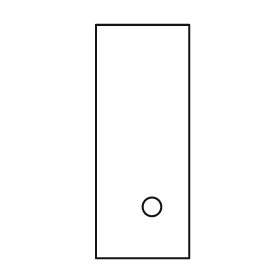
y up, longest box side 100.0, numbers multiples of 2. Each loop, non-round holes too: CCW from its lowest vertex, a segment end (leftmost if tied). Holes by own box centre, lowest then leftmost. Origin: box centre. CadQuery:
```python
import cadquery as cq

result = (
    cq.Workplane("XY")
    .moveTo(-20.0, -50.0)
    .lineTo(20.0, -50.0)
    .lineTo(20.0, 50.0)
    .lineTo(-20.0, 50.0)
    .close()
    .moveTo(4.0, -28.0)
    .circle(4.0)
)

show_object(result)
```